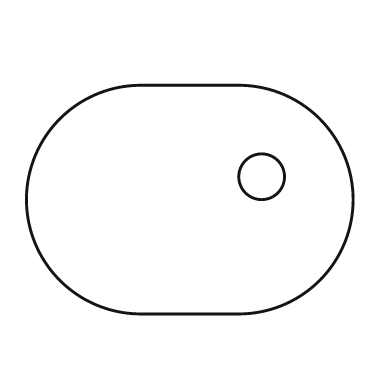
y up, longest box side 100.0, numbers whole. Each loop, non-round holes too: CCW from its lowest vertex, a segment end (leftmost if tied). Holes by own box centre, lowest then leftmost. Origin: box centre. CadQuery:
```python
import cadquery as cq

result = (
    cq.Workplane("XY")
    .moveTo(-15.0, -35.0)
    .lineTo(15.0, -35.0)
    .threePointArc((50.0, 0.0), (15.0, 35.0))
    .lineTo(-15.0, 35.0)
    .threePointArc((-50.0, 0.0), (-15.0, -35.0))
    .close()
    .moveTo(22.0, 7.0)
    .circle(7.0)
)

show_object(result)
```